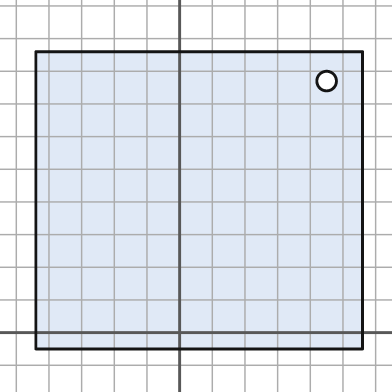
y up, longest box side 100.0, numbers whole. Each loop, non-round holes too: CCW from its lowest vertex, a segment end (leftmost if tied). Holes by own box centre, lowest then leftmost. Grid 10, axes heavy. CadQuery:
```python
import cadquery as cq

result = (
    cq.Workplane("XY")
    .moveTo(-44.0, -5.0)
    .lineTo(56.0, -5.0)
    .lineTo(56.0, 86.0)
    .lineTo(-44.0, 86.0)
    .close()
    .moveTo(45.0, 77.0)
    .circle(3.0)
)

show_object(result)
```